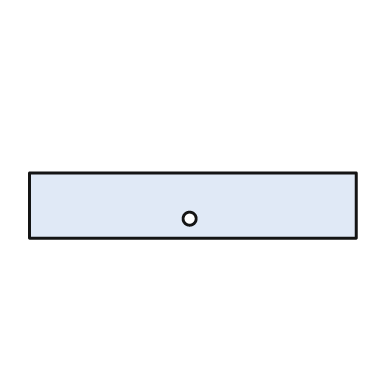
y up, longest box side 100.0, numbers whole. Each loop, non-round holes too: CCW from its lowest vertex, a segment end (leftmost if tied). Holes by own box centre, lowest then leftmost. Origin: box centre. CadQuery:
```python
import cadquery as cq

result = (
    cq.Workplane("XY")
    .moveTo(-50.0, -10.0)
    .lineTo(50.0, -10.0)
    .lineTo(50.0, 10.0)
    .lineTo(-50.0, 10.0)
    .close()
    .moveTo(-1.0, -4.0)
    .circle(2.0)
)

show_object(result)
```